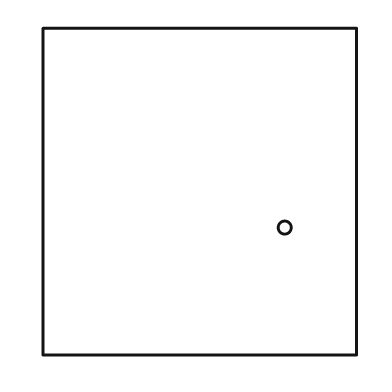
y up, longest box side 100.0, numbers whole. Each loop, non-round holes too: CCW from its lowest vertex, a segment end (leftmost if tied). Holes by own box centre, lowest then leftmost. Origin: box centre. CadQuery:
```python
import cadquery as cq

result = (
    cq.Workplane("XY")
    .moveTo(-48.0, -50.0)
    .lineTo(48.0, -50.0)
    .lineTo(48.0, 50.0)
    .lineTo(-48.0, 50.0)
    .close()
    .moveTo(26.0, -11.0)
    .circle(2.0)
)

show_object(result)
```